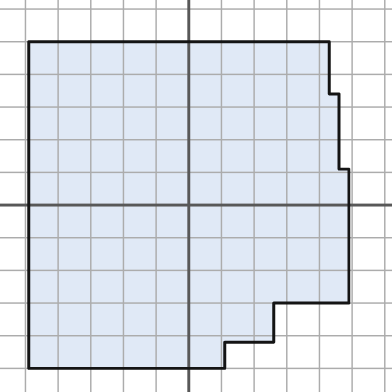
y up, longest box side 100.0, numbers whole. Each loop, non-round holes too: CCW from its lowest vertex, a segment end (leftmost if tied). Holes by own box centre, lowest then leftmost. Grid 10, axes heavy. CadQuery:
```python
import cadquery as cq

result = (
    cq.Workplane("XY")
    .moveTo(-49.0, -50.0)
    .lineTo(11.0, -50.0)
    .lineTo(11.0, -42.0)
    .lineTo(26.0, -42.0)
    .lineTo(26.0, -30.0)
    .lineTo(49.0, -30.0)
    .lineTo(49.0, 11.0)
    .lineTo(46.0, 11.0)
    .lineTo(46.0, 34.0)
    .lineTo(43.0, 34.0)
    .lineTo(43.0, 50.0)
    .lineTo(-49.0, 50.0)
    .close()
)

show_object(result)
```